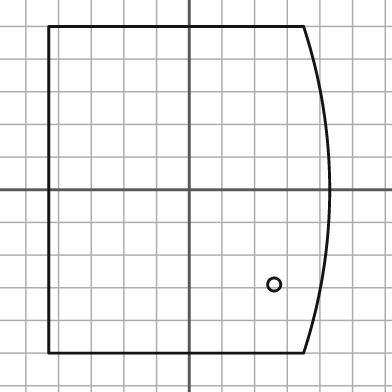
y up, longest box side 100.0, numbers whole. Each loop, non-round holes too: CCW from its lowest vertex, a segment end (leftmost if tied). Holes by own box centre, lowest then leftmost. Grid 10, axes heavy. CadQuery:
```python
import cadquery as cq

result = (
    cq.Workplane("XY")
    .moveTo(-43.0, -50.0)
    .lineTo(35.0, -50.0)
    .threePointArc((43.0, 0.0), (35.0, 50.0))
    .lineTo(-43.0, 50.0)
    .close()
    .moveTo(26.0, -29.0)
    .circle(2.0)
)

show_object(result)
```